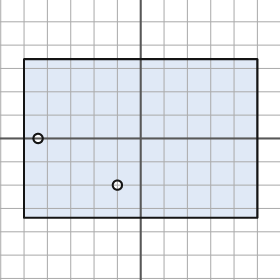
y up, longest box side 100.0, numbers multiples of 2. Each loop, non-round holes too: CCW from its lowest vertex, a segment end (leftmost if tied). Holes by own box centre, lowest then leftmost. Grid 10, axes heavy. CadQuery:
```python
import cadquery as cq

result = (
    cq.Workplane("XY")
    .moveTo(-50.0, -34.0)
    .lineTo(50.0, -34.0)
    .lineTo(50.0, 34.0)
    .lineTo(-50.0, 34.0)
    .close()
    .moveTo(-10.0, -20.0)
    .circle(2.0)
    .moveTo(-44.0, 0.0)
    .circle(2.0)
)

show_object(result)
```